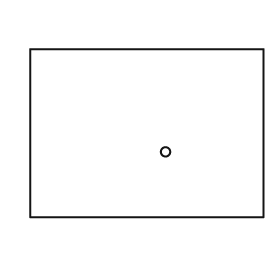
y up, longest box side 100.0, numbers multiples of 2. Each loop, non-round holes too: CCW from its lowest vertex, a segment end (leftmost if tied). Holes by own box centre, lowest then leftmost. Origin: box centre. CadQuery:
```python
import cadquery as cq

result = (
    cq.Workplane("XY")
    .moveTo(-50.0, -36.0)
    .lineTo(50.0, -36.0)
    .lineTo(50.0, 36.0)
    .lineTo(-50.0, 36.0)
    .close()
    .moveTo(8.0, -8.0)
    .circle(2.0)
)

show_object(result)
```